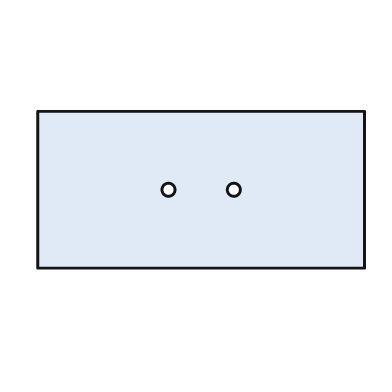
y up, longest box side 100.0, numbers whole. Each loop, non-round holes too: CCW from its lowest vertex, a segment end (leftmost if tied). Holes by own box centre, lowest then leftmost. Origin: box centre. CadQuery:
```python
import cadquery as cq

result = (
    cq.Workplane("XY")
    .moveTo(-50.0, -24.0)
    .lineTo(50.0, -24.0)
    .lineTo(50.0, 24.0)
    .lineTo(-50.0, 24.0)
    .close()
    .moveTo(-10.0, 0.0)
    .circle(2.0)
    .moveTo(10.0, 0.0)
    .circle(2.0)
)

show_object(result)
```